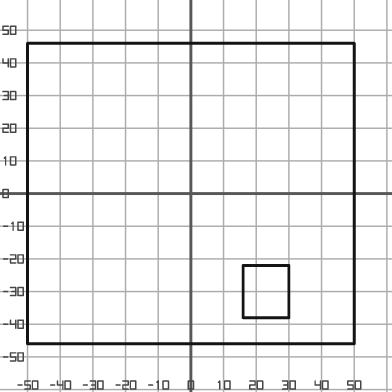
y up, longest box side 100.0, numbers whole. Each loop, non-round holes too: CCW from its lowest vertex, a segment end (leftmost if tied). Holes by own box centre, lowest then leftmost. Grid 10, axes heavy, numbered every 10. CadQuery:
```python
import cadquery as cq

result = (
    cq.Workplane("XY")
    .moveTo(-50.0, -46.0)
    .lineTo(50.0, -46.0)
    .lineTo(50.0, 46.0)
    .lineTo(-50.0, 46.0)
    .close()
    .moveTo(16.0, -38.0)
    .lineTo(30.0, -38.0)
    .lineTo(30.0, -22.0)
    .lineTo(16.0, -22.0)
    .close()
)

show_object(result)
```